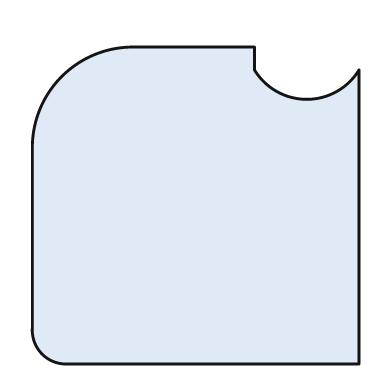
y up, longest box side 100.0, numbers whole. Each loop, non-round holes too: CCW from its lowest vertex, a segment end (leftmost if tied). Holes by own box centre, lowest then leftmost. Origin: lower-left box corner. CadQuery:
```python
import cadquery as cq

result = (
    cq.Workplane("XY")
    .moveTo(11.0, 0.0)
    .lineTo(100.0, 0.0)
    .lineTo(100.0, 90.0)
    .threePointArc((84.0, 81.0), (68.0, 90.0))
    .lineTo(68.0, 97.0)
    .lineTo(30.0, 97.0)
    .threePointArc((9.0, 88.0), (0.0, 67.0))
    .lineTo(0.0, 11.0)
    .threePointArc((3.0, 3.0), (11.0, 0.0))
    .close()
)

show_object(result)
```